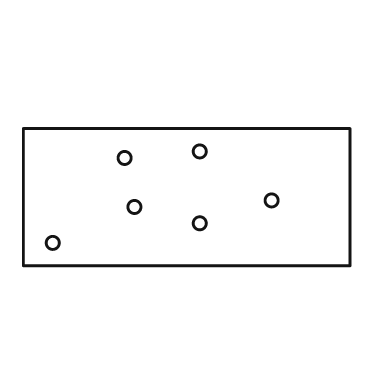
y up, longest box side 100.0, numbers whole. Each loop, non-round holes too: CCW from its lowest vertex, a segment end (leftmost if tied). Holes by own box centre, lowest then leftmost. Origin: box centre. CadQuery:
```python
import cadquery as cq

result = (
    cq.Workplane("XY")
    .moveTo(-50.0, -21.0)
    .lineTo(50.0, -21.0)
    .lineTo(50.0, 21.0)
    .lineTo(-50.0, 21.0)
    .close()
    .moveTo(-41.0, -14.0)
    .circle(2.0)
    .moveTo(4.0, -8.0)
    .circle(2.0)
    .moveTo(-16.0, -3.0)
    .circle(2.0)
    .moveTo(26.0, -1.0)
    .circle(2.0)
    .moveTo(-19.0, 12.0)
    .circle(2.0)
    .moveTo(4.0, 14.0)
    .circle(2.0)
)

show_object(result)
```